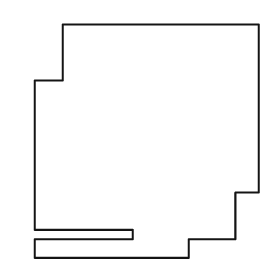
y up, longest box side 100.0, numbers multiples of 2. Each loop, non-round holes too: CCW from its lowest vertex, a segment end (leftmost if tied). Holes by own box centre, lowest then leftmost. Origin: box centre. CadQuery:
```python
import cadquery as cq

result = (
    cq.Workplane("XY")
    .moveTo(-48.0, -50.0)
    .lineTo(18.0, -50.0)
    .lineTo(18.0, -42.0)
    .lineTo(38.0, -42.0)
    .lineTo(38.0, -22.0)
    .lineTo(48.0, -22.0)
    .lineTo(48.0, 50.0)
    .lineTo(-36.0, 50.0)
    .lineTo(-36.0, 26.0)
    .lineTo(-48.0, 26.0)
    .lineTo(-48.0, -38.0)
    .lineTo(-6.0, -38.0)
    .lineTo(-6.0, -42.0)
    .lineTo(-48.0, -42.0)
    .close()
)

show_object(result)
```